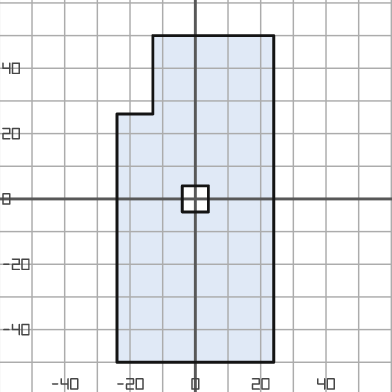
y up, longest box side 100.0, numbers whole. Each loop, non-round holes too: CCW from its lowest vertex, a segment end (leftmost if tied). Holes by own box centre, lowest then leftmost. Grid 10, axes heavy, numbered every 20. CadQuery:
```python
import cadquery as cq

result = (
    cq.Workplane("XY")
    .moveTo(-24.0, -50.0)
    .lineTo(24.0, -50.0)
    .lineTo(24.0, 50.0)
    .lineTo(-13.0, 50.0)
    .lineTo(-13.0, 26.0)
    .lineTo(-24.0, 26.0)
    .close()
    .moveTo(-4.0, -4.0)
    .lineTo(4.0, -4.0)
    .lineTo(4.0, 4.0)
    .lineTo(-4.0, 4.0)
    .close()
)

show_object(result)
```